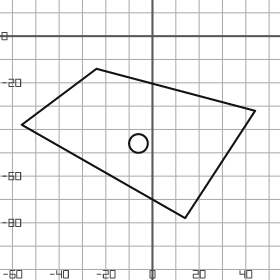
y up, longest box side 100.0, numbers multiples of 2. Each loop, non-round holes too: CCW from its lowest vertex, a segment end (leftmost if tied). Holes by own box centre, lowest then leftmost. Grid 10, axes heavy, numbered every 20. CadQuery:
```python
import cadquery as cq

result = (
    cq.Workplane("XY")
    .moveTo(14.0, -78.0)
    .lineTo(44.0, -32.0)
    .lineTo(-24.0, -14.0)
    .lineTo(-56.0, -38.0)
    .close()
    .moveTo(-6.0, -46.0)
    .circle(4.0)
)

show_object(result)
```